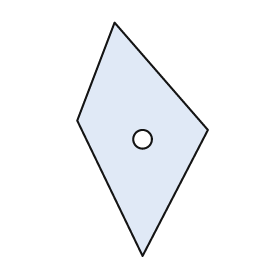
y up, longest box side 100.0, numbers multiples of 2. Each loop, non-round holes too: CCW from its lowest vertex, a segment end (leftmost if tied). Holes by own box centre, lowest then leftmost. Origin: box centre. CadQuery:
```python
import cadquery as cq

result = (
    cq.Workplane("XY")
    .moveTo(0.0, -50.0)
    .lineTo(28.0, 4.0)
    .lineTo(-12.0, 50.0)
    .lineTo(-28.0, 8.0)
    .close()
    .moveTo(0.0, 0.0)
    .circle(4.0)
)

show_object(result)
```